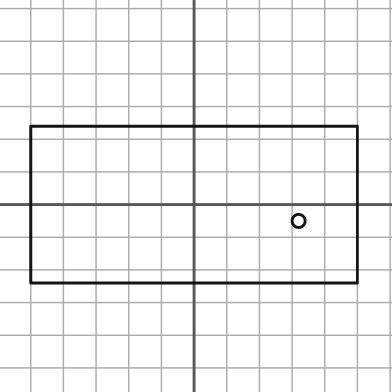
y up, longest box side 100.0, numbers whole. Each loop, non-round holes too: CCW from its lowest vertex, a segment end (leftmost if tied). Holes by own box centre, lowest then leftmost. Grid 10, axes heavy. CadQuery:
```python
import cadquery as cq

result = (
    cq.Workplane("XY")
    .moveTo(-50.0, -24.0)
    .lineTo(50.0, -24.0)
    .lineTo(50.0, 24.0)
    .lineTo(-50.0, 24.0)
    .close()
    .moveTo(32.0, -5.0)
    .circle(2.0)
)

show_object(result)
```